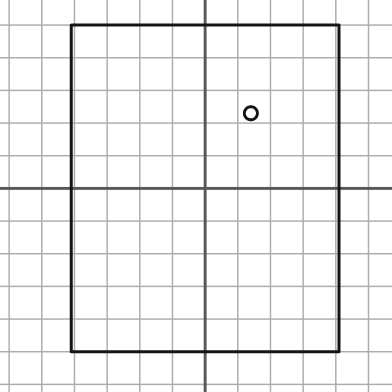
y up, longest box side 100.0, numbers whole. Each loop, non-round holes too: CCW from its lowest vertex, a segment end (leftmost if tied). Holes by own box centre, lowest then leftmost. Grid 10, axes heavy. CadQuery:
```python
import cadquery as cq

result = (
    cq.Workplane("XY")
    .moveTo(-41.0, -50.0)
    .lineTo(41.0, -50.0)
    .lineTo(41.0, 50.0)
    .lineTo(-41.0, 50.0)
    .close()
    .moveTo(14.0, 23.0)
    .circle(2.0)
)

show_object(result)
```